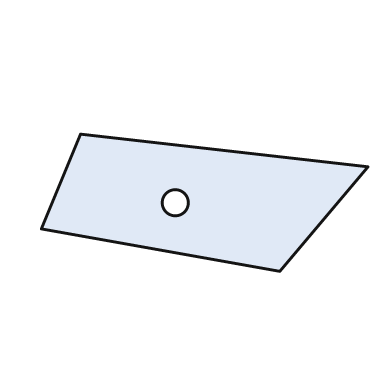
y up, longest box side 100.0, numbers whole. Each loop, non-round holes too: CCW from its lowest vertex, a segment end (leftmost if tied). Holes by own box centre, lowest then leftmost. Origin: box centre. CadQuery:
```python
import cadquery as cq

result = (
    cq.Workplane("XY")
    .moveTo(23.0, -21.0)
    .lineTo(50.0, 11.0)
    .lineTo(-38.0, 21.0)
    .lineTo(-50.0, -8.0)
    .close()
    .moveTo(-9.0, 0.0)
    .circle(4.0)
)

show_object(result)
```